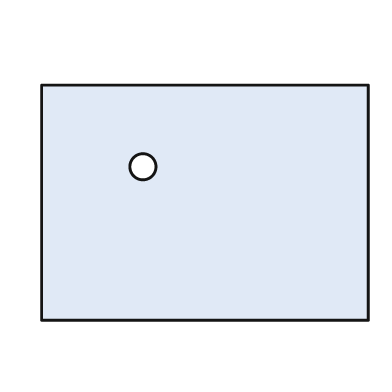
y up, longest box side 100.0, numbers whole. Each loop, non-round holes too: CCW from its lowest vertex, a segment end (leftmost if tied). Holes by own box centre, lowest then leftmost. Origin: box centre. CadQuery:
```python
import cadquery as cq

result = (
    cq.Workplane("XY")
    .moveTo(-50.0, -36.0)
    .lineTo(50.0, -36.0)
    .lineTo(50.0, 36.0)
    .lineTo(-50.0, 36.0)
    .close()
    .moveTo(-19.0, 11.0)
    .circle(4.0)
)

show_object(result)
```